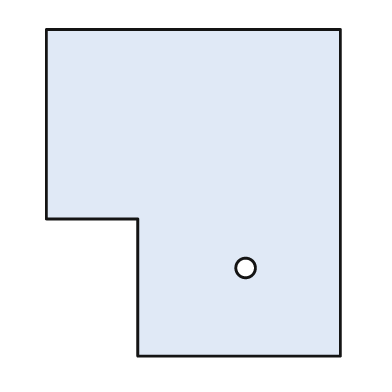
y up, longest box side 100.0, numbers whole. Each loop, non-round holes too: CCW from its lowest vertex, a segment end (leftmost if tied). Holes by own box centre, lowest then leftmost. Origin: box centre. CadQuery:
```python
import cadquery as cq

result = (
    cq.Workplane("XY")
    .moveTo(-17.0, -50.0)
    .lineTo(45.0, -50.0)
    .lineTo(45.0, 50.0)
    .lineTo(-45.0, 50.0)
    .lineTo(-45.0, -8.0)
    .lineTo(-17.0, -8.0)
    .close()
    .moveTo(16.0, -23.0)
    .circle(3.0)
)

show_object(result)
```